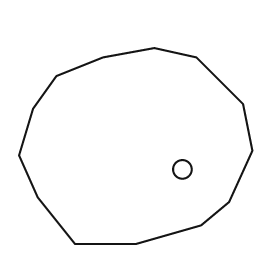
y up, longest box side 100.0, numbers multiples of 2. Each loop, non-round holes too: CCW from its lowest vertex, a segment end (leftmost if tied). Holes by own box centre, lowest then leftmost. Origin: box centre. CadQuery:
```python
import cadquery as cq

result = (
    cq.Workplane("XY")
    .moveTo(-26.0, -42.0)
    .lineTo(0.0, -42.0)
    .lineTo(28.0, -34.0)
    .lineTo(40.0, -24.0)
    .lineTo(50.0, -2.0)
    .lineTo(46.0, 18.0)
    .lineTo(26.0, 38.0)
    .lineTo(8.0, 42.0)
    .lineTo(-14.0, 38.0)
    .lineTo(-34.0, 30.0)
    .lineTo(-44.0, 16.0)
    .lineTo(-50.0, -4.0)
    .lineTo(-42.0, -22.0)
    .close()
    .moveTo(20.0, -10.0)
    .circle(4.0)
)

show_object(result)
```